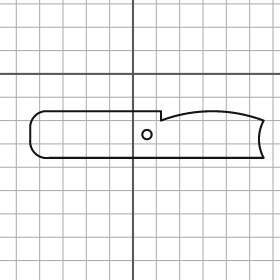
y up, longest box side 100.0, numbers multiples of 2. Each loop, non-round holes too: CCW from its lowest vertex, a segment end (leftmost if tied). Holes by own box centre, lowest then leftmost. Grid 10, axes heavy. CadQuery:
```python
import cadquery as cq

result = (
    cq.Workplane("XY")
    .moveTo(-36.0, -36.0)
    .lineTo(56.0, -36.0)
    .threePointArc((54.0, -28.0), (56.0, -20.0))
    .threePointArc((34.0, -16.0), (12.0, -20.0))
    .lineTo(12.0, -16.0)
    .lineTo(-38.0, -16.0)
    .threePointArc((-42.0, -18.0), (-44.0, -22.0))
    .lineTo(-44.0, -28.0)
    .threePointArc((-42.0, -34.0), (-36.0, -36.0))
    .close()
    .moveTo(6.0, -26.0)
    .circle(2.0)
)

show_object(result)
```